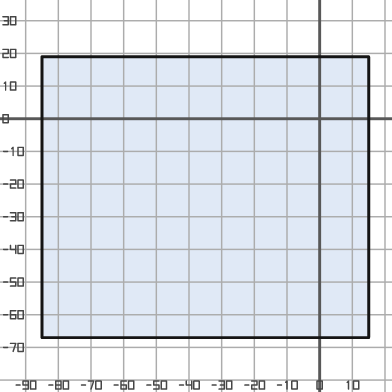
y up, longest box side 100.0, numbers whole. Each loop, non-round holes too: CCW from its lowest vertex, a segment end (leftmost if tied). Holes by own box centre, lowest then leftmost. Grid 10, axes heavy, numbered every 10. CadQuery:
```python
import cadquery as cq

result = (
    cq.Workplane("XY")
    .moveTo(-85.0, -67.0)
    .lineTo(15.0, -67.0)
    .lineTo(15.0, 19.0)
    .lineTo(-85.0, 19.0)
    .close()
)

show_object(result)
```